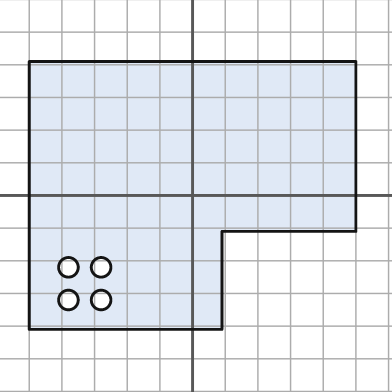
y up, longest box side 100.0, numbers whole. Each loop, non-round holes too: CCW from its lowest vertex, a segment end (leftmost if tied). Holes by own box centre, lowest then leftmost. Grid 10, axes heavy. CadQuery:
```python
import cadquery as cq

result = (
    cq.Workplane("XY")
    .moveTo(-50.0, -41.0)
    .lineTo(9.0, -41.0)
    .lineTo(9.0, -11.0)
    .lineTo(50.0, -11.0)
    .lineTo(50.0, 41.0)
    .lineTo(-50.0, 41.0)
    .close()
    .moveTo(-38.0, -32.0)
    .circle(3.0)
    .moveTo(-28.0, -32.0)
    .circle(3.0)
    .moveTo(-38.0, -22.0)
    .circle(3.0)
    .moveTo(-28.0, -22.0)
    .circle(3.0)
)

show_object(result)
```